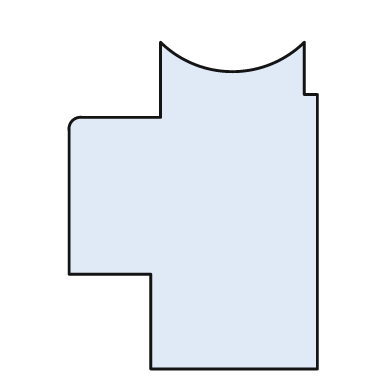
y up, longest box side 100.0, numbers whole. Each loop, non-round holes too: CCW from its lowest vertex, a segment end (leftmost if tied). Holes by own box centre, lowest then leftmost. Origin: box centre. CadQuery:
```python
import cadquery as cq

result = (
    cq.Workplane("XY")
    .moveTo(-13.0, -50.0)
    .lineTo(38.0, -50.0)
    .lineTo(38.0, 34.0)
    .lineTo(34.0, 34.0)
    .lineTo(34.0, 50.0)
    .threePointArc((12.0, 41.0), (-10.0, 50.0))
    .lineTo(-10.0, 27.0)
    .lineTo(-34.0, 27.0)
    .threePointArc((-37.0, 26.0), (-38.0, 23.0))
    .lineTo(-38.0, -21.0)
    .lineTo(-13.0, -21.0)
    .close()
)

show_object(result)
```